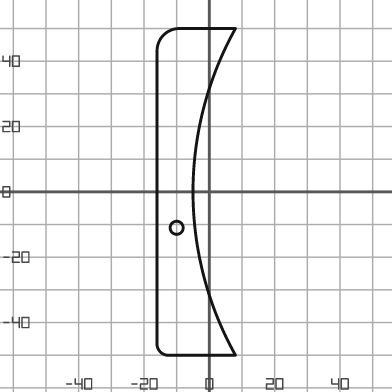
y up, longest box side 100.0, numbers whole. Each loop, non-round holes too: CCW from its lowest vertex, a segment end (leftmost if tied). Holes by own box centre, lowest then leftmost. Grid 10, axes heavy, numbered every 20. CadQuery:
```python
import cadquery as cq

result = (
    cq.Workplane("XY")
    .moveTo(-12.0, -50.0)
    .lineTo(8.0, -50.0)
    .threePointArc((-5.0, 0.0), (8.0, 50.0))
    .lineTo(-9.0, 50.0)
    .threePointArc((-14.0, 48.0), (-16.0, 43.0))
    .lineTo(-16.0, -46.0)
    .threePointArc((-15.0, -49.0), (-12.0, -50.0))
    .close()
    .moveTo(-10.0, -11.0)
    .circle(2.0)
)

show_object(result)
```